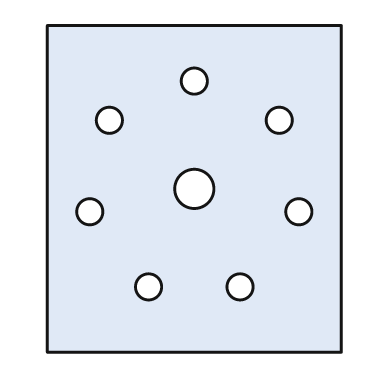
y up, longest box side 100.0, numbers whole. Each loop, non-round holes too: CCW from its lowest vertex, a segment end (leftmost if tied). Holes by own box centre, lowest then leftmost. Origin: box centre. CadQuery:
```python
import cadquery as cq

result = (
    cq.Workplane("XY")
    .moveTo(-45.0, -50.0)
    .lineTo(45.0, -50.0)
    .lineTo(45.0, 50.0)
    .lineTo(-45.0, 50.0)
    .close()
    .moveTo(-14.0, -30.0)
    .circle(4.0)
    .moveTo(14.0, -30.0)
    .circle(4.0)
    .moveTo(-32.0, -7.0)
    .circle(4.0)
    .moveTo(32.0, -7.0)
    .circle(4.0)
    .moveTo(0.0, 0.0)
    .circle(6.0)
    .moveTo(-26.0, 21.0)
    .circle(4.0)
    .moveTo(26.0, 21.0)
    .circle(4.0)
    .moveTo(0.0, 33.0)
    .circle(4.0)
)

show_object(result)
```